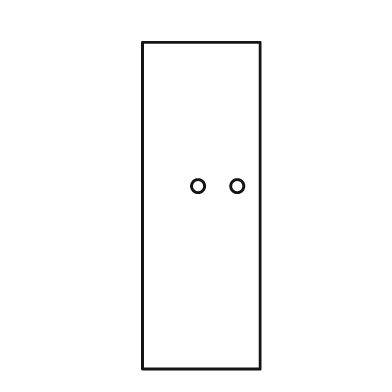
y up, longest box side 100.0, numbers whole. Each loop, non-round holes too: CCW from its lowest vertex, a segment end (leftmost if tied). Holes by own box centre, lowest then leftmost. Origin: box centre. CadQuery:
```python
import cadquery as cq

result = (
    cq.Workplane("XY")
    .moveTo(-18.0, -50.0)
    .lineTo(18.0, -50.0)
    .lineTo(18.0, 50.0)
    .lineTo(-18.0, 50.0)
    .close()
    .moveTo(-1.0, 6.0)
    .circle(2.0)
    .moveTo(11.0, 6.0)
    .circle(2.0)
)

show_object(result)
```